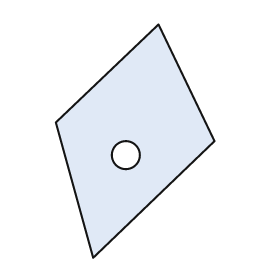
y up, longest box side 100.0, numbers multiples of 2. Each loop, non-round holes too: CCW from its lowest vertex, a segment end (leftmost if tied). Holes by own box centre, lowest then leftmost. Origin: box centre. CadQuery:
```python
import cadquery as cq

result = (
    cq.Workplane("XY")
    .moveTo(-18.0, -50.0)
    .lineTo(34.0, 0.0)
    .lineTo(10.0, 50.0)
    .lineTo(-34.0, 8.0)
    .close()
    .moveTo(-4.0, -6.0)
    .circle(6.0)
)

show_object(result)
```